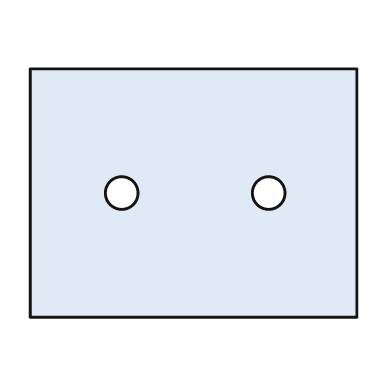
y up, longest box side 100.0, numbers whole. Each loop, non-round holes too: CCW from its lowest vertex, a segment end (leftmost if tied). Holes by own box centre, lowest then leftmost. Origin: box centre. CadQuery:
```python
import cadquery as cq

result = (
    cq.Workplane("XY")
    .moveTo(-50.0, -38.0)
    .lineTo(50.0, -38.0)
    .lineTo(50.0, 38.0)
    .lineTo(-50.0, 38.0)
    .close()
    .moveTo(-22.0, 0.0)
    .circle(5.0)
    .moveTo(23.0, 0.0)
    .circle(5.0)
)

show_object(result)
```